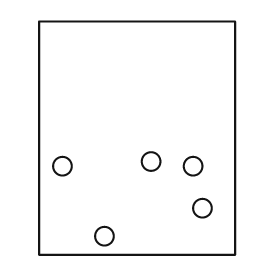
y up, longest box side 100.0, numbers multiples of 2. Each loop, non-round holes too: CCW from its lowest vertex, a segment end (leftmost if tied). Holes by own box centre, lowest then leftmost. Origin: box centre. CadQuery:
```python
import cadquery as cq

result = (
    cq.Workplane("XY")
    .moveTo(-42.0, -50.0)
    .lineTo(42.0, -50.0)
    .lineTo(42.0, 50.0)
    .lineTo(-42.0, 50.0)
    .close()
    .moveTo(-14.0, -42.0)
    .circle(4.0)
    .moveTo(28.0, -30.0)
    .circle(4.0)
    .moveTo(-32.0, -12.0)
    .circle(4.0)
    .moveTo(24.0, -12.0)
    .circle(4.0)
    .moveTo(6.0, -10.0)
    .circle(4.0)
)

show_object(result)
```